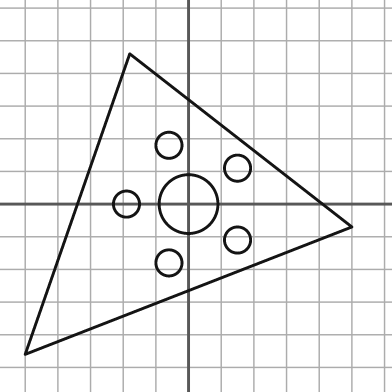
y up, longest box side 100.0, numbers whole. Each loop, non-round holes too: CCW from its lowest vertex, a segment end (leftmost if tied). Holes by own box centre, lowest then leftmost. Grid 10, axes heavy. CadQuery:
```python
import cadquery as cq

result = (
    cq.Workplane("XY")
    .moveTo(-50.0, -46.0)
    .lineTo(50.0, -7.0)
    .lineTo(-18.0, 46.0)
    .close()
    .moveTo(-6.0, -18.0)
    .circle(4.0)
    .moveTo(15.0, -11.0)
    .circle(4.0)
    .moveTo(-19.0, 0.0)
    .circle(4.0)
    .moveTo(0.0, 0.0)
    .circle(9.0)
    .moveTo(15.0, 11.0)
    .circle(4.0)
    .moveTo(-6.0, 18.0)
    .circle(4.0)
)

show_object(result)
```